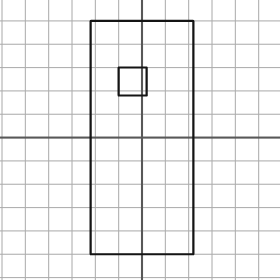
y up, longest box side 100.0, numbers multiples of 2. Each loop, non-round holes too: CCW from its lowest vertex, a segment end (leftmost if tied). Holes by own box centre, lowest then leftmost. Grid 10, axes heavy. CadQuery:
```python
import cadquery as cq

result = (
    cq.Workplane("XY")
    .moveTo(-22.0, -50.0)
    .lineTo(22.0, -50.0)
    .lineTo(22.0, 50.0)
    .lineTo(-22.0, 50.0)
    .close()
    .moveTo(-10.0, 18.0)
    .lineTo(2.0, 18.0)
    .lineTo(2.0, 30.0)
    .lineTo(-10.0, 30.0)
    .close()
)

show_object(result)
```